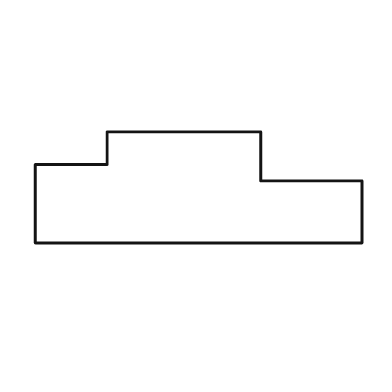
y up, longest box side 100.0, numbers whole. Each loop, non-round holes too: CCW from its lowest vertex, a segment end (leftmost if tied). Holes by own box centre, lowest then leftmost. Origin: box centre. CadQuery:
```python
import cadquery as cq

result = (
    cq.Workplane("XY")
    .moveTo(-50.0, -17.0)
    .lineTo(50.0, -17.0)
    .lineTo(50.0, 2.0)
    .lineTo(19.0, 2.0)
    .lineTo(19.0, 17.0)
    .lineTo(-28.0, 17.0)
    .lineTo(-28.0, 7.0)
    .lineTo(-50.0, 7.0)
    .close()
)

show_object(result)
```